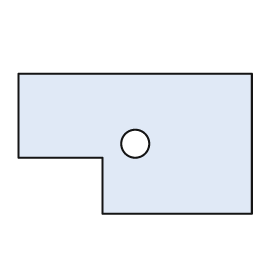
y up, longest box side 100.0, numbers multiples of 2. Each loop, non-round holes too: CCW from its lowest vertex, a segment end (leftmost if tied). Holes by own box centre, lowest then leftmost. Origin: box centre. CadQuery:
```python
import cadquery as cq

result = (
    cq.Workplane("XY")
    .moveTo(-14.0, -30.0)
    .lineTo(50.0, -30.0)
    .lineTo(50.0, 30.0)
    .lineTo(-50.0, 30.0)
    .lineTo(-50.0, -6.0)
    .lineTo(-14.0, -6.0)
    .close()
    .moveTo(0.0, 0.0)
    .circle(6.0)
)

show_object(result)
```